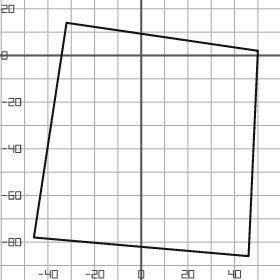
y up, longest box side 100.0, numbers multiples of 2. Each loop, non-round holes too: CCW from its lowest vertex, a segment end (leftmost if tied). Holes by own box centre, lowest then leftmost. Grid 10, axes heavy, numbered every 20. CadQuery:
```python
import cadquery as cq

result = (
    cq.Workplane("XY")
    .moveTo(46.0, -86.0)
    .lineTo(50.0, 2.0)
    .lineTo(-32.0, 14.0)
    .lineTo(-46.0, -78.0)
    .close()
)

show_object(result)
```